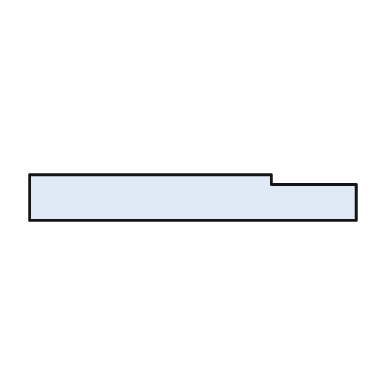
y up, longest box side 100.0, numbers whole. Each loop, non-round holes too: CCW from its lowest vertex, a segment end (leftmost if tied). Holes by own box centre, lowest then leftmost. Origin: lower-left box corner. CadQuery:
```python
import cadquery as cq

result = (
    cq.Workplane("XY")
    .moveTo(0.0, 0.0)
    .lineTo(100.0, 0.0)
    .lineTo(100.0, 11.0)
    .lineTo(74.0, 11.0)
    .lineTo(74.0, 14.0)
    .lineTo(0.0, 14.0)
    .close()
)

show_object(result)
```